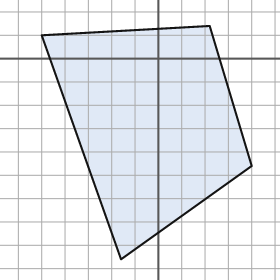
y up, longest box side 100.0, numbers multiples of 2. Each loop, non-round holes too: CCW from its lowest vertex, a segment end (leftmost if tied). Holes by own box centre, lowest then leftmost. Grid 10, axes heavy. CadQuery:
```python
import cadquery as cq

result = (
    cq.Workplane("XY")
    .moveTo(-16.0, -86.0)
    .lineTo(40.0, -46.0)
    .lineTo(22.0, 14.0)
    .lineTo(-50.0, 10.0)
    .close()
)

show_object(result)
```